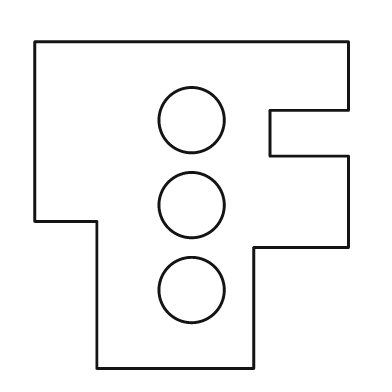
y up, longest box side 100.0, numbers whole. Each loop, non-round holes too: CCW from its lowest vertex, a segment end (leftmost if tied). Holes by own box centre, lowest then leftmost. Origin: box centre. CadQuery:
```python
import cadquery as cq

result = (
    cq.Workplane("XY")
    .moveTo(-29.0, -50.0)
    .lineTo(19.0, -50.0)
    .lineTo(19.0, -13.0)
    .lineTo(48.0, -13.0)
    .lineTo(48.0, 15.0)
    .lineTo(24.0, 15.0)
    .lineTo(24.0, 29.0)
    .lineTo(48.0, 29.0)
    .lineTo(48.0, 50.0)
    .lineTo(-48.0, 50.0)
    .lineTo(-48.0, -5.0)
    .lineTo(-29.0, -5.0)
    .close()
    .moveTo(0.0, -26.0)
    .circle(10.0)
    .moveTo(0.0, 0.0)
    .circle(10.0)
    .moveTo(0.0, 26.0)
    .circle(10.0)
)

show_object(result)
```